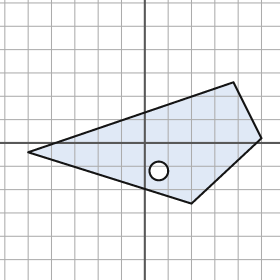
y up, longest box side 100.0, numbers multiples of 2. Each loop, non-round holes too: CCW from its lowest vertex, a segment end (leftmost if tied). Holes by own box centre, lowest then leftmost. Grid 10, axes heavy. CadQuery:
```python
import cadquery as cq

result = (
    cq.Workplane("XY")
    .moveTo(20.0, -26.0)
    .lineTo(50.0, 2.0)
    .lineTo(38.0, 26.0)
    .lineTo(-50.0, -4.0)
    .close()
    .moveTo(6.0, -12.0)
    .circle(4.0)
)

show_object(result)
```